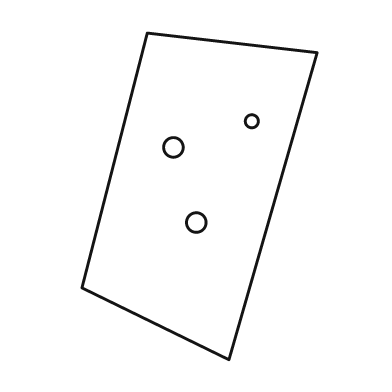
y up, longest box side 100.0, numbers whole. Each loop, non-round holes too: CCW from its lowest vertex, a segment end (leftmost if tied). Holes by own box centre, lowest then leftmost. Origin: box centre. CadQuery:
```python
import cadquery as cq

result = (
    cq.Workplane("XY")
    .moveTo(9.0, -50.0)
    .lineTo(36.0, 44.0)
    .lineTo(-16.0, 50.0)
    .lineTo(-36.0, -28.0)
    .close()
    .moveTo(-1.0, -8.0)
    .circle(3.0)
    .moveTo(-8.0, 15.0)
    .circle(3.0)
    .moveTo(16.0, 23.0)
    .circle(2.0)
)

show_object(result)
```